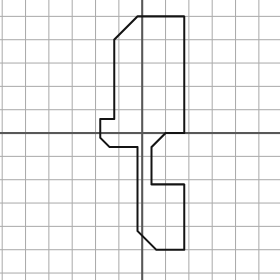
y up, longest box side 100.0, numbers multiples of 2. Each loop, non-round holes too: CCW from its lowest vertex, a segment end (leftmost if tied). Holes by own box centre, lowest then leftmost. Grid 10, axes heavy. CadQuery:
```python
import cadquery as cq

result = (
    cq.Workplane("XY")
    .moveTo(6.0, -50.0)
    .lineTo(18.0, -50.0)
    .lineTo(18.0, -22.0)
    .lineTo(4.0, -22.0)
    .lineTo(4.0, -6.0)
    .lineTo(10.0, 0.0)
    .lineTo(18.0, 0.0)
    .lineTo(18.0, 50.0)
    .lineTo(-2.0, 50.0)
    .lineTo(-12.0, 40.0)
    .lineTo(-12.0, 6.0)
    .lineTo(-18.0, 6.0)
    .lineTo(-18.0, -2.0)
    .lineTo(-14.0, -6.0)
    .lineTo(-2.0, -6.0)
    .lineTo(-2.0, -42.0)
    .close()
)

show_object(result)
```